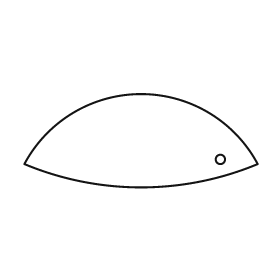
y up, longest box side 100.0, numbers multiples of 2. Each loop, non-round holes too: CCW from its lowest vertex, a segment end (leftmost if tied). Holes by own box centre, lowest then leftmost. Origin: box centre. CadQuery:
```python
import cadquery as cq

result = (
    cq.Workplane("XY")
    .moveTo(-50.0, -10.0)
    .threePointArc((0.0, -20.0), (50.0, -10.0))
    .threePointArc((0.0, 20.0), (-50.0, -10.0))
    .close()
    .moveTo(34.0, -8.0)
    .circle(2.0)
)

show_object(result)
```